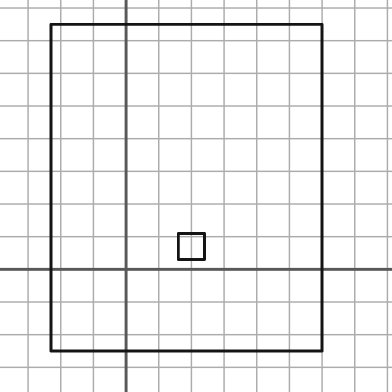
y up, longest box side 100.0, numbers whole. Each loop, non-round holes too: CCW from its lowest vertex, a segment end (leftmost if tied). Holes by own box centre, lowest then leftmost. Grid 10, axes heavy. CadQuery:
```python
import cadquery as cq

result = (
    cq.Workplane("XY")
    .moveTo(-23.0, -25.0)
    .lineTo(60.0, -25.0)
    .lineTo(60.0, 75.0)
    .lineTo(-23.0, 75.0)
    .close()
    .moveTo(16.0, 3.0)
    .lineTo(24.0, 3.0)
    .lineTo(24.0, 11.0)
    .lineTo(16.0, 11.0)
    .close()
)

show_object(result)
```